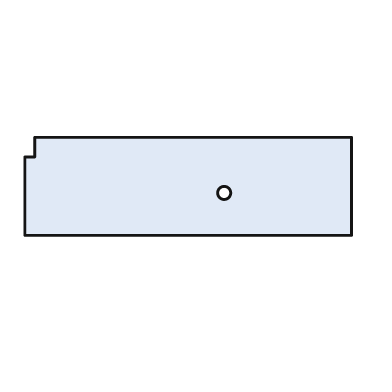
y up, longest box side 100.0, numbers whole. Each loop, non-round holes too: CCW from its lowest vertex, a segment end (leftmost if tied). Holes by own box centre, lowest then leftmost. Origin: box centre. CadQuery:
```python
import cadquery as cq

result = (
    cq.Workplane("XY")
    .moveTo(-50.0, -15.0)
    .lineTo(50.0, -15.0)
    .lineTo(50.0, 15.0)
    .lineTo(-47.0, 15.0)
    .lineTo(-47.0, 9.0)
    .lineTo(-50.0, 9.0)
    .close()
    .moveTo(11.0, -2.0)
    .circle(2.0)
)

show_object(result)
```